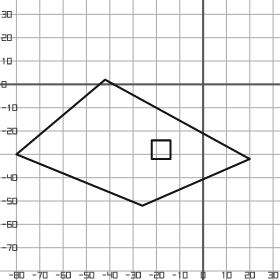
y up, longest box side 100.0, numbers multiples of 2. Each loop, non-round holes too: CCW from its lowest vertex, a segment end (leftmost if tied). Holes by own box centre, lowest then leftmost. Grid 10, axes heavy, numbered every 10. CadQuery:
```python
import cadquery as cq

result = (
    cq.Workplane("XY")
    .moveTo(-26.0, -52.0)
    .lineTo(20.0, -32.0)
    .lineTo(-42.0, 2.0)
    .lineTo(-80.0, -30.0)
    .close()
    .moveTo(-22.0, -32.0)
    .lineTo(-14.0, -32.0)
    .lineTo(-14.0, -24.0)
    .lineTo(-22.0, -24.0)
    .close()
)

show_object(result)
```